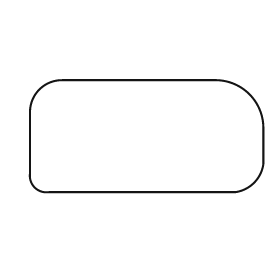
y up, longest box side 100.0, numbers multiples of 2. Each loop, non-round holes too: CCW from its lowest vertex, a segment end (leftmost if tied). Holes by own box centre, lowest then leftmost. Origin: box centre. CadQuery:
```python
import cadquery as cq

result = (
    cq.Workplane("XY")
    .moveTo(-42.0, -24.0)
    .lineTo(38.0, -24.0)
    .threePointArc((46.0, -20.0), (50.0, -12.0))
    .lineTo(50.0, 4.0)
    .threePointArc((44.0, 18.0), (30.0, 24.0))
    .lineTo(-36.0, 24.0)
    .threePointArc((-46.0, 20.0), (-50.0, 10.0))
    .lineTo(-50.0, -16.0)
    .threePointArc((-48.0, -22.0), (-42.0, -24.0))
    .close()
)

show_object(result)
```